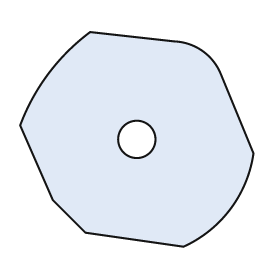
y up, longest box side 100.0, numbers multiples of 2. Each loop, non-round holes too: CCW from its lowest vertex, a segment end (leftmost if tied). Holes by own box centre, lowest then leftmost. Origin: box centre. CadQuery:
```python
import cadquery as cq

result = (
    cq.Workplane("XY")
    .moveTo(20.0, -46.0)
    .threePointArc((40.0, -30.0), (50.0, -6.0))
    .lineTo(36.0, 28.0)
    .threePointArc((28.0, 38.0), (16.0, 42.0))
    .lineTo(-20.0, 46.0)
    .threePointArc((-38.0, 28.0), (-50.0, 6.0))
    .lineTo(-36.0, -26.0)
    .lineTo(-22.0, -40.0)
    .close()
    .moveTo(0.0, 0.0)
    .circle(8.0)
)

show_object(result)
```